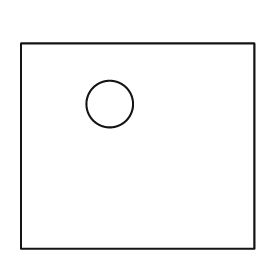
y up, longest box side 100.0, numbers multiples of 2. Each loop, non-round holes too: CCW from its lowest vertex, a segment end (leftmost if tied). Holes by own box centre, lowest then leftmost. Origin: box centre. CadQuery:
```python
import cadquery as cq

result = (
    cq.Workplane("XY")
    .moveTo(-50.0, -44.0)
    .lineTo(50.0, -44.0)
    .lineTo(50.0, 44.0)
    .lineTo(-50.0, 44.0)
    .close()
    .moveTo(-12.0, 18.0)
    .circle(10.0)
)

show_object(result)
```